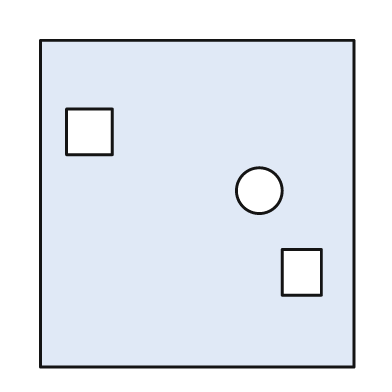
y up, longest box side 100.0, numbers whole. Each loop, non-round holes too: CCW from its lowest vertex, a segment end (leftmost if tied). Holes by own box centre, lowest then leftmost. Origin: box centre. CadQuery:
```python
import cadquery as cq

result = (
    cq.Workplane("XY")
    .moveTo(-48.0, -50.0)
    .lineTo(48.0, -50.0)
    .lineTo(48.0, 50.0)
    .lineTo(-48.0, 50.0)
    .close()
    .moveTo(26.0, -28.0)
    .lineTo(38.0, -28.0)
    .lineTo(38.0, -14.0)
    .lineTo(26.0, -14.0)
    .close()
    .moveTo(19.0, 4.0)
    .circle(7.0)
    .moveTo(-40.0, 15.0)
    .lineTo(-26.0, 15.0)
    .lineTo(-26.0, 29.0)
    .lineTo(-40.0, 29.0)
    .close()
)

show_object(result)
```